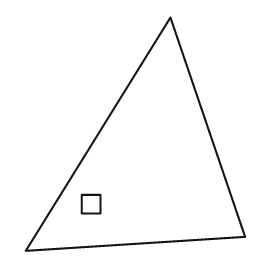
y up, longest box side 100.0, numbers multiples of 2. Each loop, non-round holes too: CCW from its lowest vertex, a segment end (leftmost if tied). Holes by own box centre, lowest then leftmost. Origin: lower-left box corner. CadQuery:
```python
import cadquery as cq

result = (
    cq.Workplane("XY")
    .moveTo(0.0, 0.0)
    .lineTo(94.0, 6.0)
    .lineTo(62.0, 100.0)
    .close()
    .moveTo(24.0, 16.0)
    .lineTo(32.0, 16.0)
    .lineTo(32.0, 24.0)
    .lineTo(24.0, 24.0)
    .close()
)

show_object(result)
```